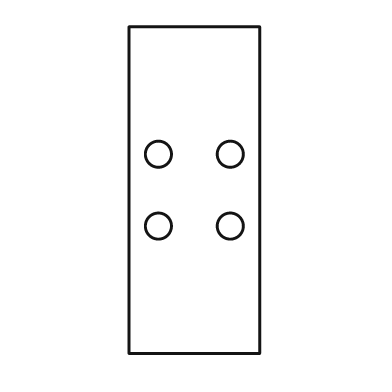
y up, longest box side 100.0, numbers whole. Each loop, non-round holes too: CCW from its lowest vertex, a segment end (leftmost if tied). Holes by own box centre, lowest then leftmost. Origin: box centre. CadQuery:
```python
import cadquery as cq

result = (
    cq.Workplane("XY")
    .moveTo(-20.0, -50.0)
    .lineTo(20.0, -50.0)
    .lineTo(20.0, 50.0)
    .lineTo(-20.0, 50.0)
    .close()
    .moveTo(-11.0, -11.0)
    .circle(4.0)
    .moveTo(11.0, -11.0)
    .circle(4.0)
    .moveTo(-11.0, 11.0)
    .circle(4.0)
    .moveTo(11.0, 11.0)
    .circle(4.0)
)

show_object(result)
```